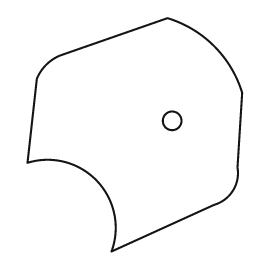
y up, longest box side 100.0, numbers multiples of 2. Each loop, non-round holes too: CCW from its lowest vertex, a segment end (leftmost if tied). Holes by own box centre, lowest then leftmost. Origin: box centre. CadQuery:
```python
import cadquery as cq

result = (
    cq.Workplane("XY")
    .moveTo(-10.0, -50.0)
    .lineTo(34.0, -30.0)
    .threePointArc((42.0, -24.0), (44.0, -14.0))
    .lineTo(46.0, 18.0)
    .threePointArc((34.0, 38.0), (14.0, 50.0))
    .lineTo(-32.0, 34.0)
    .threePointArc((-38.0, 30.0), (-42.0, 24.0))
    .lineTo(-46.0, -12.0)
    .threePointArc((-16.0, -20.0), (-10.0, -50.0))
    .close()
    .moveTo(16.0, 6.0)
    .circle(4.0)
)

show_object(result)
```